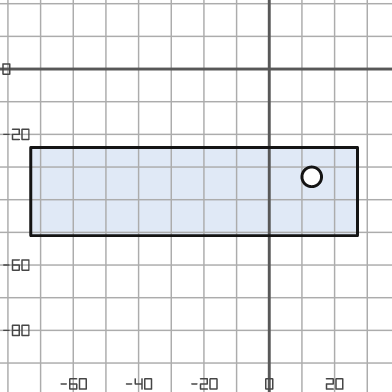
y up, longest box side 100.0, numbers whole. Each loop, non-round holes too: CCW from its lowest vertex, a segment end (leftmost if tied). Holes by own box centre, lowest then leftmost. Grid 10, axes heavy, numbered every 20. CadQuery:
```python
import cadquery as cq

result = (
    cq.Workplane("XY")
    .moveTo(-73.0, -51.0)
    .lineTo(27.0, -51.0)
    .lineTo(27.0, -24.0)
    .lineTo(-73.0, -24.0)
    .close()
    .moveTo(13.0, -33.0)
    .circle(3.0)
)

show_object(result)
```